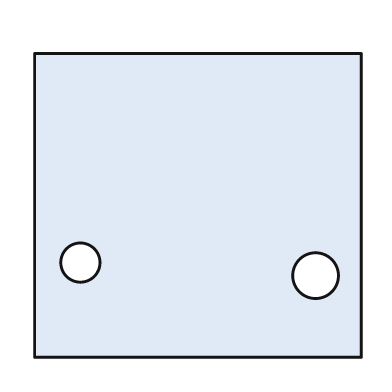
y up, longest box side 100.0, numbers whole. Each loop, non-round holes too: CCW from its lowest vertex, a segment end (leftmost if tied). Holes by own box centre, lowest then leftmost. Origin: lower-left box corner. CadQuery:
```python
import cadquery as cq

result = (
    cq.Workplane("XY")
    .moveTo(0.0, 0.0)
    .lineTo(100.0, 0.0)
    .lineTo(100.0, 93.0)
    .lineTo(0.0, 93.0)
    .close()
    .moveTo(86.0, 25.0)
    .circle(7.0)
    .moveTo(14.0, 29.0)
    .circle(6.0)
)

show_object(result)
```